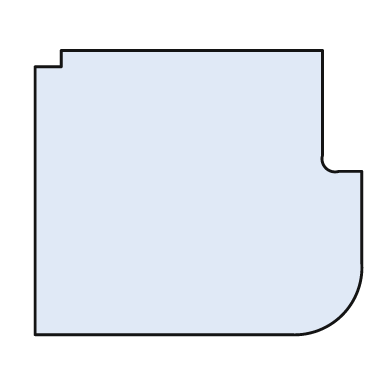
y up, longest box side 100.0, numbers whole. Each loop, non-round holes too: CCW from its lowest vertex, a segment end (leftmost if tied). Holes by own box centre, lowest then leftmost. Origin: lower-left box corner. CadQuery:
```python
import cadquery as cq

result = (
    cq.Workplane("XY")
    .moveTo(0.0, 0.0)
    .lineTo(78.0, 0.0)
    .threePointArc((94.0, 6.0), (100.0, 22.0))
    .lineTo(100.0, 50.0)
    .lineTo(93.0, 50.0)
    .threePointArc((89.0, 51.0), (88.0, 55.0))
    .lineTo(88.0, 87.0)
    .lineTo(8.0, 87.0)
    .lineTo(8.0, 82.0)
    .lineTo(0.0, 82.0)
    .close()
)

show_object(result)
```